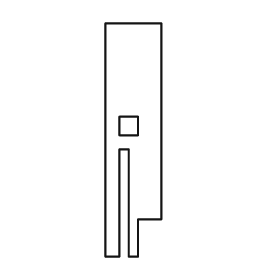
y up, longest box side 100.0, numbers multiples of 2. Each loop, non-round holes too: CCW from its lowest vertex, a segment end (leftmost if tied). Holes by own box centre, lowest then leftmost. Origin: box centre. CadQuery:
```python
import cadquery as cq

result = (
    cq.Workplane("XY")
    .moveTo(-12.0, -50.0)
    .lineTo(-6.0, -50.0)
    .lineTo(-6.0, -4.0)
    .lineTo(-2.0, -4.0)
    .lineTo(-2.0, -50.0)
    .lineTo(2.0, -50.0)
    .lineTo(2.0, -34.0)
    .lineTo(12.0, -34.0)
    .lineTo(12.0, 50.0)
    .lineTo(-12.0, 50.0)
    .close()
    .moveTo(-6.0, 2.0)
    .lineTo(2.0, 2.0)
    .lineTo(2.0, 10.0)
    .lineTo(-6.0, 10.0)
    .close()
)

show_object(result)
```